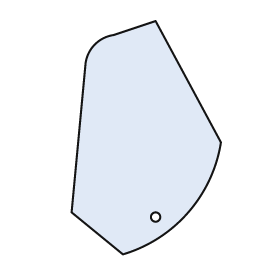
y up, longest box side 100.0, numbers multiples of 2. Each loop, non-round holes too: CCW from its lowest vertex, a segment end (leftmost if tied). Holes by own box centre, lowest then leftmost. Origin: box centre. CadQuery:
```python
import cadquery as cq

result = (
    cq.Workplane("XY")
    .moveTo(-10.0, -50.0)
    .threePointArc((18.0, -32.0), (32.0, -2.0))
    .lineTo(4.0, 50.0)
    .lineTo(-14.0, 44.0)
    .threePointArc((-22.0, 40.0), (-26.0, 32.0))
    .lineTo(-32.0, -32.0)
    .close()
    .moveTo(4.0, -34.0)
    .circle(2.0)
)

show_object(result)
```